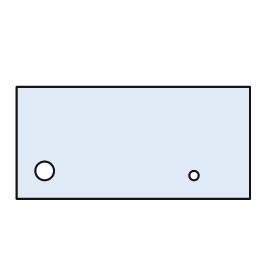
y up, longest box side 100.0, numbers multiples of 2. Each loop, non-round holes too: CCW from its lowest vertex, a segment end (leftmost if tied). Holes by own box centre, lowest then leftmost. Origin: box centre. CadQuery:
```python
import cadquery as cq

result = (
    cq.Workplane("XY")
    .moveTo(-50.0, -24.0)
    .lineTo(50.0, -24.0)
    .lineTo(50.0, 24.0)
    .lineTo(-50.0, 24.0)
    .close()
    .moveTo(26.0, -14.0)
    .circle(2.0)
    .moveTo(-38.0, -12.0)
    .circle(4.0)
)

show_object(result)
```